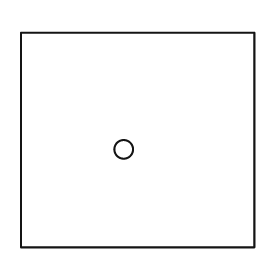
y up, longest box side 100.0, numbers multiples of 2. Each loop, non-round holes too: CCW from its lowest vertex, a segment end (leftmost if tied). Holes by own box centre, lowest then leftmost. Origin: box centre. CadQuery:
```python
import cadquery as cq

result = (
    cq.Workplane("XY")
    .moveTo(-50.0, -46.0)
    .lineTo(50.0, -46.0)
    .lineTo(50.0, 46.0)
    .lineTo(-50.0, 46.0)
    .close()
    .moveTo(-6.0, -4.0)
    .circle(4.0)
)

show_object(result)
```